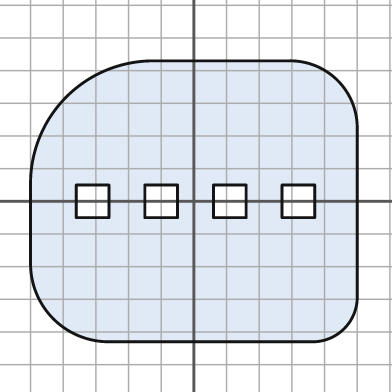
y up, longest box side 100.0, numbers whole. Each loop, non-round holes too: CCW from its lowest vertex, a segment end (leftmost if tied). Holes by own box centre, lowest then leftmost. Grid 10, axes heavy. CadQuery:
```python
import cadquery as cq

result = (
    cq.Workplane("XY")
    .moveTo(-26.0, -43.0)
    .lineTo(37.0, -43.0)
    .threePointArc((46.0, -39.0), (50.0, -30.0))
    .lineTo(50.0, 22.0)
    .threePointArc((44.0, 37.0), (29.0, 43.0))
    .lineTo(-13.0, 43.0)
    .threePointArc((-39.0, 32.0), (-50.0, 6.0))
    .lineTo(-50.0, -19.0)
    .threePointArc((-43.0, -36.0), (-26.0, -43.0))
    .close()
    .moveTo(-36.0, -5.0)
    .lineTo(-26.0, -5.0)
    .lineTo(-26.0, 5.0)
    .lineTo(-36.0, 5.0)
    .close()
    .moveTo(-15.0, -5.0)
    .lineTo(-5.0, -5.0)
    .lineTo(-5.0, 5.0)
    .lineTo(-15.0, 5.0)
    .close()
    .moveTo(6.0, -5.0)
    .lineTo(16.0, -5.0)
    .lineTo(16.0, 5.0)
    .lineTo(6.0, 5.0)
    .close()
    .moveTo(27.0, -5.0)
    .lineTo(37.0, -5.0)
    .lineTo(37.0, 5.0)
    .lineTo(27.0, 5.0)
    .close()
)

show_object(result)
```